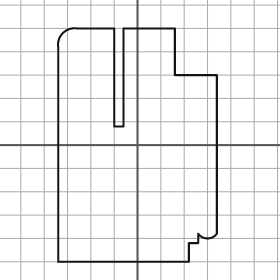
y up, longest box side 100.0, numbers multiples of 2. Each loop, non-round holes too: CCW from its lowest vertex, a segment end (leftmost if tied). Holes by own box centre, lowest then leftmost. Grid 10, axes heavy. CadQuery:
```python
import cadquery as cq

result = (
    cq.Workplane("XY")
    .moveTo(-34.0, -50.0)
    .lineTo(22.0, -50.0)
    .lineTo(22.0, -42.0)
    .lineTo(26.0, -42.0)
    .lineTo(26.0, -38.0)
    .threePointArc((30.0, -40.0), (34.0, -38.0))
    .lineTo(34.0, 30.0)
    .lineTo(16.0, 30.0)
    .lineTo(16.0, 50.0)
    .lineTo(-6.0, 50.0)
    .lineTo(-6.0, 8.0)
    .lineTo(-10.0, 8.0)
    .lineTo(-10.0, 50.0)
    .lineTo(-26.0, 50.0)
    .threePointArc((-32.0, 48.0), (-34.0, 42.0))
    .close()
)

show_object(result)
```